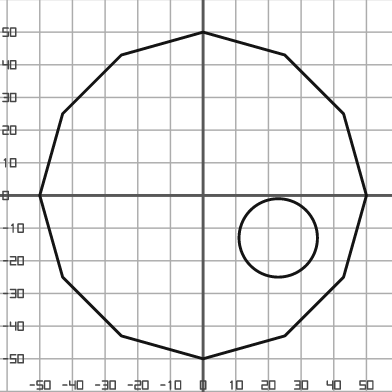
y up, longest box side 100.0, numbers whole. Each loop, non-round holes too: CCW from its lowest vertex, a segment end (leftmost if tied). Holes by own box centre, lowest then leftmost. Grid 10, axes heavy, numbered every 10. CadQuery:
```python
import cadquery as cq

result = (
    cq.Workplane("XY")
    .moveTo(0.0, -50.0)
    .lineTo(25.0, -43.0)
    .lineTo(43.0, -25.0)
    .lineTo(50.0, 0.0)
    .lineTo(43.0, 25.0)
    .lineTo(25.0, 43.0)
    .lineTo(0.0, 50.0)
    .lineTo(-25.0, 43.0)
    .lineTo(-43.0, 25.0)
    .lineTo(-50.0, 0.0)
    .lineTo(-43.0, -25.0)
    .lineTo(-25.0, -43.0)
    .close()
    .moveTo(23.0, -13.0)
    .circle(12.0)
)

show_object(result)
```